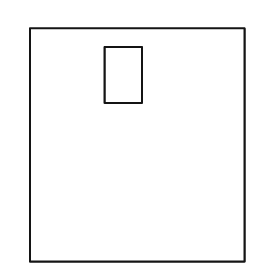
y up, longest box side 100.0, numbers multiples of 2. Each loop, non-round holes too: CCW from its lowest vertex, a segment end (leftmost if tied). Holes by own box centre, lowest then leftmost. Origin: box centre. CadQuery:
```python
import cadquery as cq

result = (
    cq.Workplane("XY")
    .moveTo(-46.0, -50.0)
    .lineTo(46.0, -50.0)
    .lineTo(46.0, 50.0)
    .lineTo(-46.0, 50.0)
    .close()
    .moveTo(-14.0, 18.0)
    .lineTo(2.0, 18.0)
    .lineTo(2.0, 42.0)
    .lineTo(-14.0, 42.0)
    .close()
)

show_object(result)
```